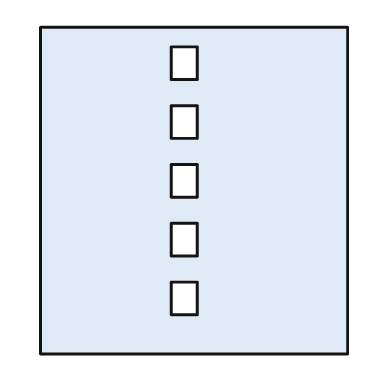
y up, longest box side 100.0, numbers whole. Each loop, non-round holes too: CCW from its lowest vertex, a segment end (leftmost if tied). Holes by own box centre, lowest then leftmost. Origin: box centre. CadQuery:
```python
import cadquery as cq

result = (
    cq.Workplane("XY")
    .moveTo(-47.0, -50.0)
    .lineTo(47.0, -50.0)
    .lineTo(47.0, 50.0)
    .lineTo(-47.0, 50.0)
    .close()
    .moveTo(-7.0, -38.0)
    .lineTo(1.0, -38.0)
    .lineTo(1.0, -28.0)
    .lineTo(-7.0, -28.0)
    .close()
    .moveTo(-7.0, -20.0)
    .lineTo(1.0, -20.0)
    .lineTo(1.0, -10.0)
    .lineTo(-7.0, -10.0)
    .close()
    .moveTo(-7.0, -2.0)
    .lineTo(1.0, -2.0)
    .lineTo(1.0, 8.0)
    .lineTo(-7.0, 8.0)
    .close()
    .moveTo(-7.0, 16.0)
    .lineTo(1.0, 16.0)
    .lineTo(1.0, 26.0)
    .lineTo(-7.0, 26.0)
    .close()
    .moveTo(-7.0, 34.0)
    .lineTo(1.0, 34.0)
    .lineTo(1.0, 44.0)
    .lineTo(-7.0, 44.0)
    .close()
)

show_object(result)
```